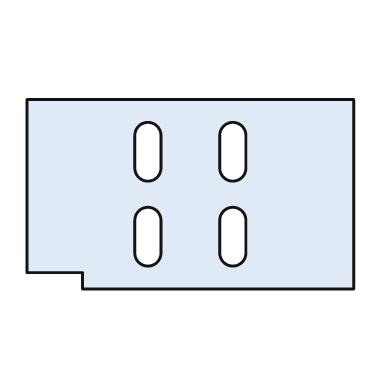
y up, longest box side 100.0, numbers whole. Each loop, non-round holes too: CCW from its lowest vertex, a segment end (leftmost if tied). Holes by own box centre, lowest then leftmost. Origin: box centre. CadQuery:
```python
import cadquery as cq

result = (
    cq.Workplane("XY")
    .moveTo(-33.0, -29.0)
    .lineTo(50.0, -29.0)
    .lineTo(50.0, 29.0)
    .lineTo(-50.0, 29.0)
    .lineTo(-50.0, -24.0)
    .lineTo(-33.0, -24.0)
    .close()
    .moveTo(-17.0, -18.0)
    .threePointArc((-13.0, -22.0), (-9.0, -18.0))
    .lineTo(-9.0, -8.0)
    .threePointArc((-13.0, -4.0), (-17.0, -8.0))
    .close()
    .moveTo(9.0, -18.0)
    .threePointArc((13.0, -22.0), (17.0, -18.0))
    .lineTo(17.0, -8.0)
    .threePointArc((13.0, -4.0), (9.0, -8.0))
    .close()
    .moveTo(-17.0, 8.0)
    .threePointArc((-13.0, 4.0), (-9.0, 8.0))
    .lineTo(-9.0, 18.0)
    .threePointArc((-13.0, 22.0), (-17.0, 18.0))
    .close()
    .moveTo(9.0, 8.0)
    .threePointArc((13.0, 4.0), (17.0, 8.0))
    .lineTo(17.0, 18.0)
    .threePointArc((13.0, 22.0), (9.0, 18.0))
    .close()
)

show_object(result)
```